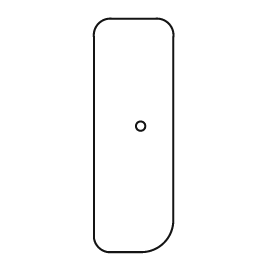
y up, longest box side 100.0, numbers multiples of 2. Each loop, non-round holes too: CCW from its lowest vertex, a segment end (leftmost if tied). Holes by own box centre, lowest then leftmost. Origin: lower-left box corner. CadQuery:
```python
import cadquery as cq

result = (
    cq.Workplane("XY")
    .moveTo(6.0, 0.0)
    .lineTo(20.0, 0.0)
    .threePointArc((30.0, 4.0), (34.0, 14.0))
    .lineTo(34.0, 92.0)
    .threePointArc((32.0, 98.0), (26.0, 100.0))
    .lineTo(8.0, 100.0)
    .threePointArc((2.0, 98.0), (0.0, 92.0))
    .lineTo(0.0, 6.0)
    .threePointArc((2.0, 2.0), (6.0, 0.0))
    .close()
    .moveTo(20.0, 54.0)
    .circle(2.0)
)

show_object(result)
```